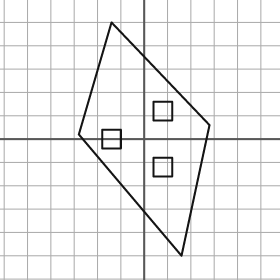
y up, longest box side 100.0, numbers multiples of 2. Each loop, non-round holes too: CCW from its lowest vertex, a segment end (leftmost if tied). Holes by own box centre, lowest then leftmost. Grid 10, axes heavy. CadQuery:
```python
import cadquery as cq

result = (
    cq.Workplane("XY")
    .moveTo(16.0, -50.0)
    .lineTo(28.0, 6.0)
    .lineTo(-14.0, 50.0)
    .lineTo(-28.0, 2.0)
    .close()
    .moveTo(4.0, -16.0)
    .lineTo(12.0, -16.0)
    .lineTo(12.0, -8.0)
    .lineTo(4.0, -8.0)
    .close()
    .moveTo(-18.0, -4.0)
    .lineTo(-10.0, -4.0)
    .lineTo(-10.0, 4.0)
    .lineTo(-18.0, 4.0)
    .close()
    .moveTo(4.0, 8.0)
    .lineTo(12.0, 8.0)
    .lineTo(12.0, 16.0)
    .lineTo(4.0, 16.0)
    .close()
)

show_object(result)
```